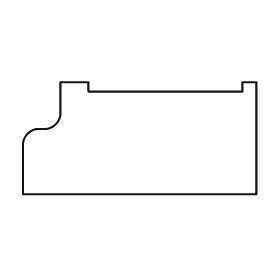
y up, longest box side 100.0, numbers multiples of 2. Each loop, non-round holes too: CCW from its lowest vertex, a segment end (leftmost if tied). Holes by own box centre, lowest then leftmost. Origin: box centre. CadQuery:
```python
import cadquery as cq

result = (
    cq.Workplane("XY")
    .moveTo(-50.0, -24.0)
    .lineTo(50.0, -24.0)
    .lineTo(50.0, 24.0)
    .lineTo(44.0, 24.0)
    .lineTo(44.0, 20.0)
    .lineTo(-22.0, 20.0)
    .lineTo(-22.0, 24.0)
    .lineTo(-34.0, 24.0)
    .lineTo(-34.0, 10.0)
    .threePointArc((-36.0, 6.0), (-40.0, 4.0))
    .lineTo(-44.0, 4.0)
    .threePointArc((-48.0, 2.0), (-50.0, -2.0))
    .close()
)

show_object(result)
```